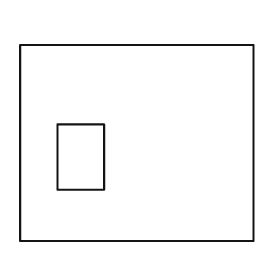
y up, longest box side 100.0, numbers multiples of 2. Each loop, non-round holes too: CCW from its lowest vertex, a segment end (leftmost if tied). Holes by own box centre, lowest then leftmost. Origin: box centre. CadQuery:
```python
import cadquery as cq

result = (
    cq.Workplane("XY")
    .moveTo(-50.0, -42.0)
    .lineTo(50.0, -42.0)
    .lineTo(50.0, 42.0)
    .lineTo(-50.0, 42.0)
    .close()
    .moveTo(-34.0, -20.0)
    .lineTo(-14.0, -20.0)
    .lineTo(-14.0, 8.0)
    .lineTo(-34.0, 8.0)
    .close()
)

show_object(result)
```